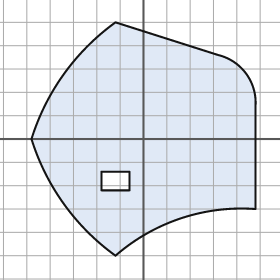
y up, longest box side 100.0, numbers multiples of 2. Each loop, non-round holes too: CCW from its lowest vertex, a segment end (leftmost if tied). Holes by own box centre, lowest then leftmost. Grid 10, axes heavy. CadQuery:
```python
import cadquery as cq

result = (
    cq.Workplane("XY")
    .moveTo(-12.0, -50.0)
    .threePointArc((16.0, -34.0), (48.0, -30.0))
    .lineTo(48.0, 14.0)
    .threePointArc((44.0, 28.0), (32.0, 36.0))
    .lineTo(-12.0, 50.0)
    .threePointArc((-34.0, 28.0), (-48.0, 0.0))
    .threePointArc((-34.0, -28.0), (-12.0, -50.0))
    .close()
    .moveTo(-18.0, -22.0)
    .lineTo(-6.0, -22.0)
    .lineTo(-6.0, -14.0)
    .lineTo(-18.0, -14.0)
    .close()
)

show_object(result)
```